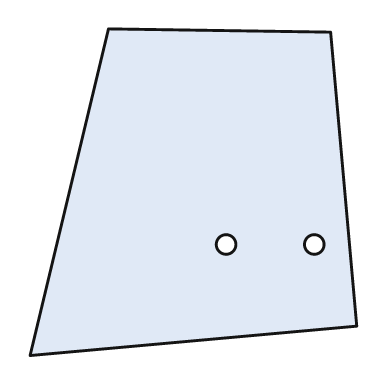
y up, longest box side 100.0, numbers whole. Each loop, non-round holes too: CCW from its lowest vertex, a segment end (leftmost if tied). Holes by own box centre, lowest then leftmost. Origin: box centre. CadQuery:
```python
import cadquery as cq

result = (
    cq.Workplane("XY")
    .moveTo(-50.0, -50.0)
    .lineTo(50.0, -41.0)
    .lineTo(42.0, 49.0)
    .lineTo(-26.0, 50.0)
    .close()
    .moveTo(10.0, -16.0)
    .circle(3.0)
    .moveTo(37.0, -16.0)
    .circle(3.0)
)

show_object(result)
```